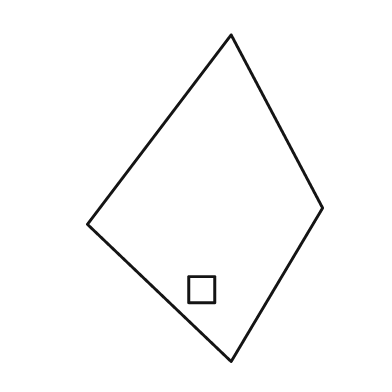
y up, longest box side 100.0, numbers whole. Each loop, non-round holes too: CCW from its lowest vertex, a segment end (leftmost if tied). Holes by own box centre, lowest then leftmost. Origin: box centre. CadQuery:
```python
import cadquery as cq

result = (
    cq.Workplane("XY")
    .moveTo(8.0, -50.0)
    .lineTo(36.0, -3.0)
    .lineTo(8.0, 50.0)
    .lineTo(-36.0, -8.0)
    .close()
    .moveTo(-5.0, -32.0)
    .lineTo(3.0, -32.0)
    .lineTo(3.0, -24.0)
    .lineTo(-5.0, -24.0)
    .close()
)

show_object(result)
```